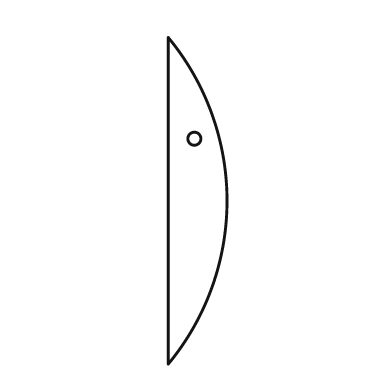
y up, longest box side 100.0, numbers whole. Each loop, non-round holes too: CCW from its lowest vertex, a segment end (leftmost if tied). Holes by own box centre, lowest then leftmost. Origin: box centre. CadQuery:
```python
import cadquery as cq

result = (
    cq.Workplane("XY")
    .moveTo(-9.0, -50.0)
    .threePointArc((9.0, 0.0), (-9.0, 50.0))
    .close()
    .moveTo(-1.0, 19.0)
    .circle(2.0)
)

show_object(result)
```